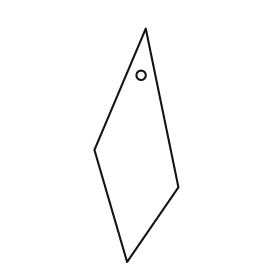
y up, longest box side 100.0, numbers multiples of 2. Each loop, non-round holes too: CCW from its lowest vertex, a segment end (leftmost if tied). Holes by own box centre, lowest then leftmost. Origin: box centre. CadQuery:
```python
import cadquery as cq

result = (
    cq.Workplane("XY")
    .moveTo(-4.0, -50.0)
    .lineTo(18.0, -18.0)
    .lineTo(4.0, 50.0)
    .lineTo(-18.0, -2.0)
    .close()
    .moveTo(2.0, 30.0)
    .circle(2.0)
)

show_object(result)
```